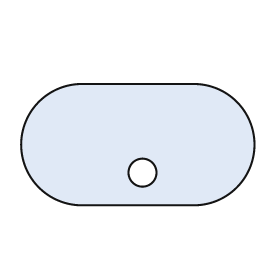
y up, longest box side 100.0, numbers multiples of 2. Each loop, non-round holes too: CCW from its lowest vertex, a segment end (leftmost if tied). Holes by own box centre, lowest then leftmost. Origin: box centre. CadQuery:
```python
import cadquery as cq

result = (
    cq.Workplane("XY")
    .moveTo(-24.0, -26.0)
    .lineTo(24.0, -26.0)
    .threePointArc((50.0, 0.0), (24.0, 26.0))
    .lineTo(-24.0, 26.0)
    .threePointArc((-50.0, 0.0), (-24.0, -26.0))
    .close()
    .moveTo(2.0, -12.0)
    .circle(6.0)
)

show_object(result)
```